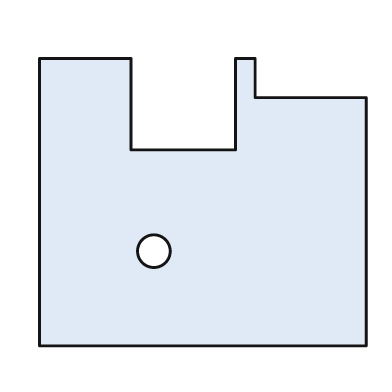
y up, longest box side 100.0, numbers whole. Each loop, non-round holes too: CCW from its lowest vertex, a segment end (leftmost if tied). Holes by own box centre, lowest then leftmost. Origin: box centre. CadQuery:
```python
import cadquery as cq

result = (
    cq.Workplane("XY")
    .moveTo(-50.0, -44.0)
    .lineTo(50.0, -44.0)
    .lineTo(50.0, 32.0)
    .lineTo(16.0, 32.0)
    .lineTo(16.0, 44.0)
    .lineTo(10.0, 44.0)
    .lineTo(10.0, 16.0)
    .lineTo(-22.0, 16.0)
    .lineTo(-22.0, 44.0)
    .lineTo(-50.0, 44.0)
    .close()
    .moveTo(-15.0, -15.0)
    .circle(5.0)
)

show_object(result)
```